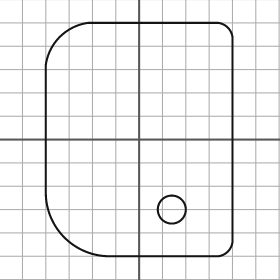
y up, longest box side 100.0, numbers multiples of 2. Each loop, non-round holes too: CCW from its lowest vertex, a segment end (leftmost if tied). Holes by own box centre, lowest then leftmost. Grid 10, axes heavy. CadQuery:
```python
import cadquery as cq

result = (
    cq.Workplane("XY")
    .moveTo(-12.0, -50.0)
    .lineTo(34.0, -50.0)
    .threePointArc((38.0, -48.0), (40.0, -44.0))
    .lineTo(40.0, 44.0)
    .threePointArc((38.0, 48.0), (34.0, 50.0))
    .lineTo(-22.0, 50.0)
    .threePointArc((-34.0, 44.0), (-40.0, 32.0))
    .lineTo(-40.0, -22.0)
    .threePointArc((-32.0, -42.0), (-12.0, -50.0))
    .close()
    .moveTo(14.0, -30.0)
    .circle(6.0)
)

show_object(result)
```